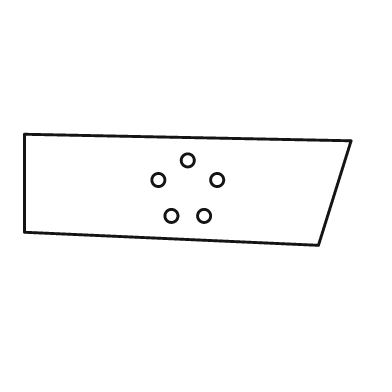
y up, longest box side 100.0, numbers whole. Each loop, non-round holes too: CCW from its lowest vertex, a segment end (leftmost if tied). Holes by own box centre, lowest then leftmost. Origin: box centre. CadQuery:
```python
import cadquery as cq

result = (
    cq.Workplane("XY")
    .moveTo(40.0, -17.0)
    .lineTo(50.0, 15.0)
    .lineTo(-50.0, 17.0)
    .lineTo(-50.0, -13.0)
    .close()
    .moveTo(-5.0, -8.0)
    .circle(2.0)
    .moveTo(5.0, -8.0)
    .circle(2.0)
    .moveTo(-9.0, 3.0)
    .circle(2.0)
    .moveTo(9.0, 3.0)
    .circle(2.0)
    .moveTo(0.0, 9.0)
    .circle(2.0)
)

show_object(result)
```